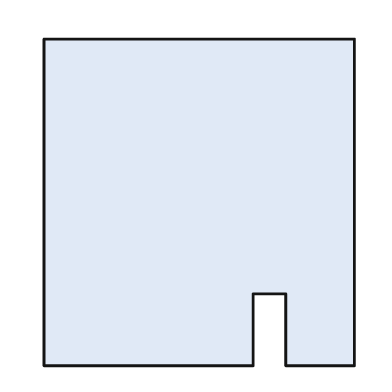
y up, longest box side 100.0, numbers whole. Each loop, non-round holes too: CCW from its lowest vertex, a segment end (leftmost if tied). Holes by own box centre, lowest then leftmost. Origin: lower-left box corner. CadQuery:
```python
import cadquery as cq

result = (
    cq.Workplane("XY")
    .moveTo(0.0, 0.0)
    .lineTo(64.0, 0.0)
    .lineTo(64.0, 22.0)
    .lineTo(74.0, 22.0)
    .lineTo(74.0, 0.0)
    .lineTo(95.0, 0.0)
    .lineTo(95.0, 100.0)
    .lineTo(0.0, 100.0)
    .close()
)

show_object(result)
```